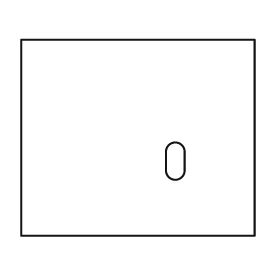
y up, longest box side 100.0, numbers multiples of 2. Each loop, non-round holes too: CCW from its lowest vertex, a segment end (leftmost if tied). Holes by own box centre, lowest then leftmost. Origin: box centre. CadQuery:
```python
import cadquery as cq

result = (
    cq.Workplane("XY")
    .moveTo(-50.0, -42.0)
    .lineTo(50.0, -42.0)
    .lineTo(50.0, 42.0)
    .lineTo(-50.0, 42.0)
    .close()
    .moveTo(12.0, -14.0)
    .threePointArc((16.0, -18.0), (20.0, -14.0))
    .lineTo(20.0, -6.0)
    .threePointArc((16.0, -2.0), (12.0, -6.0))
    .close()
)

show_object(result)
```